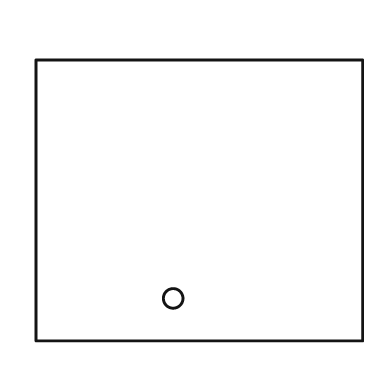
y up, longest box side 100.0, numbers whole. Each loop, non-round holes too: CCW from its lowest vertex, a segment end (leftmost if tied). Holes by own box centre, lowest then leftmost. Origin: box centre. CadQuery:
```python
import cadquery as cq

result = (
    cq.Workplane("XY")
    .moveTo(-50.0, -43.0)
    .lineTo(50.0, -43.0)
    .lineTo(50.0, 43.0)
    .lineTo(-50.0, 43.0)
    .close()
    .moveTo(-8.0, -30.0)
    .circle(3.0)
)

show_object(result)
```